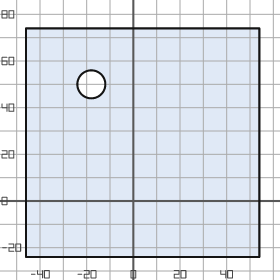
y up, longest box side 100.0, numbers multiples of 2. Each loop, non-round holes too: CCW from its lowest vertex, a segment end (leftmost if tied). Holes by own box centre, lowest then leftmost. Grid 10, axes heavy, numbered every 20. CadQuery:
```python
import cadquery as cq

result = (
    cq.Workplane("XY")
    .moveTo(-46.0, -24.0)
    .lineTo(54.0, -24.0)
    .lineTo(54.0, 74.0)
    .lineTo(-46.0, 74.0)
    .close()
    .moveTo(-18.0, 50.0)
    .circle(6.0)
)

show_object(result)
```